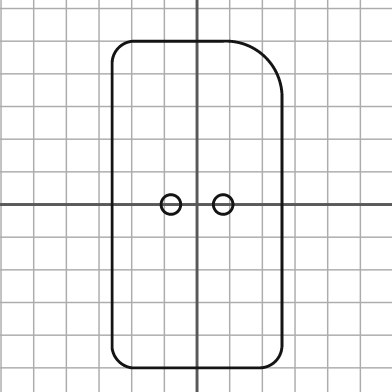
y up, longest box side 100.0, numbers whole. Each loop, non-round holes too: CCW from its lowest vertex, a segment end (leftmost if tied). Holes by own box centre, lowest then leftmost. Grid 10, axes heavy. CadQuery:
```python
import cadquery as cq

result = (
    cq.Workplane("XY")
    .moveTo(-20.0, -50.0)
    .lineTo(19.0, -50.0)
    .threePointArc((24.0, -48.0), (26.0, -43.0))
    .lineTo(26.0, 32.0)
    .threePointArc((21.0, 45.0), (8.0, 50.0))
    .lineTo(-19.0, 50.0)
    .threePointArc((-24.0, 48.0), (-26.0, 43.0))
    .lineTo(-26.0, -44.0)
    .threePointArc((-24.0, -48.0), (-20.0, -50.0))
    .close()
    .moveTo(-8.0, 0.0)
    .circle(3.0)
    .moveTo(8.0, 0.0)
    .circle(3.0)
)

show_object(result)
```